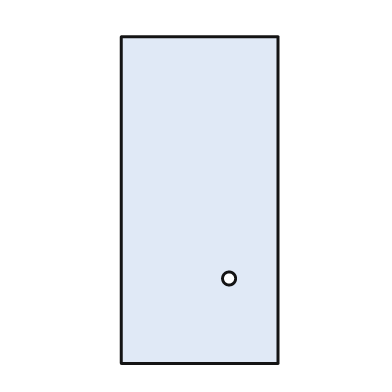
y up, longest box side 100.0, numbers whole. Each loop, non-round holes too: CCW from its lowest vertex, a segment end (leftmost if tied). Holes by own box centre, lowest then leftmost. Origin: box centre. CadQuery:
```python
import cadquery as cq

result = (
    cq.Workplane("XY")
    .moveTo(-24.0, -50.0)
    .lineTo(24.0, -50.0)
    .lineTo(24.0, 50.0)
    .lineTo(-24.0, 50.0)
    .close()
    .moveTo(9.0, -24.0)
    .circle(2.0)
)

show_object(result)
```